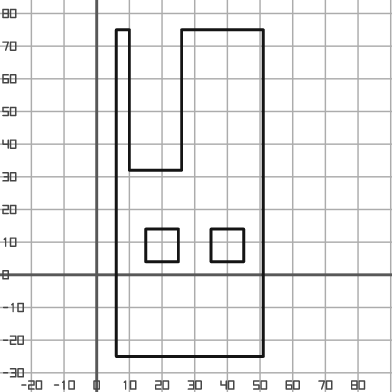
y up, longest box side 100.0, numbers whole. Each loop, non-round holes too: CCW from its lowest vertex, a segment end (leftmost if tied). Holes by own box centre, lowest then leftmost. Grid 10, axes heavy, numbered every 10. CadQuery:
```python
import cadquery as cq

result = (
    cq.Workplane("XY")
    .moveTo(6.0, -25.0)
    .lineTo(51.0, -25.0)
    .lineTo(51.0, 75.0)
    .lineTo(26.0, 75.0)
    .lineTo(26.0, 32.0)
    .lineTo(10.0, 32.0)
    .lineTo(10.0, 75.0)
    .lineTo(6.0, 75.0)
    .close()
    .moveTo(15.0, 4.0)
    .lineTo(25.0, 4.0)
    .lineTo(25.0, 14.0)
    .lineTo(15.0, 14.0)
    .close()
    .moveTo(35.0, 4.0)
    .lineTo(45.0, 4.0)
    .lineTo(45.0, 14.0)
    .lineTo(35.0, 14.0)
    .close()
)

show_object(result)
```